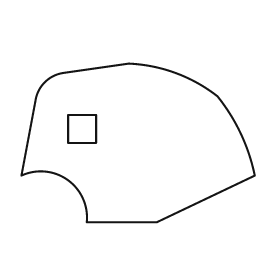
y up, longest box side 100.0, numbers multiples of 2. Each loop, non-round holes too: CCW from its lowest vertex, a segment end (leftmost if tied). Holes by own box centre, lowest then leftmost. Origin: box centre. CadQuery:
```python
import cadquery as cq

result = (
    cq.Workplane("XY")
    .moveTo(-22.0, -34.0)
    .lineTo(8.0, -34.0)
    .lineTo(50.0, -14.0)
    .threePointArc((44.0, 4.0), (34.0, 20.0))
    .threePointArc((16.0, 30.0), (-4.0, 34.0))
    .lineTo(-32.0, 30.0)
    .threePointArc((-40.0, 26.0), (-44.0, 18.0))
    .lineTo(-50.0, -14.0)
    .threePointArc((-30.0, -16.0), (-22.0, -34.0))
    .close()
    .moveTo(-30.0, 0.0)
    .lineTo(-18.0, 0.0)
    .lineTo(-18.0, 12.0)
    .lineTo(-30.0, 12.0)
    .close()
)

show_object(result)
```